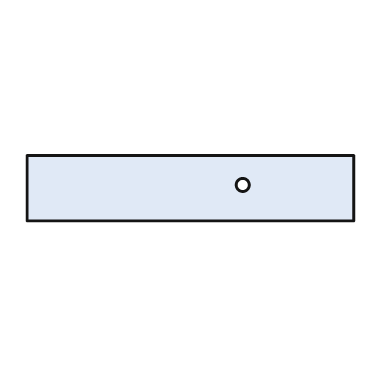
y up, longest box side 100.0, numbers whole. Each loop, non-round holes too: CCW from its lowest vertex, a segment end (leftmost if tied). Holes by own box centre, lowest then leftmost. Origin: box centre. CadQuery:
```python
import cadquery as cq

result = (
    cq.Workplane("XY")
    .moveTo(-50.0, -10.0)
    .lineTo(50.0, -10.0)
    .lineTo(50.0, 10.0)
    .lineTo(-50.0, 10.0)
    .close()
    .moveTo(16.0, 1.0)
    .circle(2.0)
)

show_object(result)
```